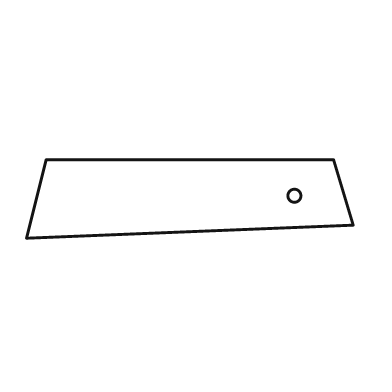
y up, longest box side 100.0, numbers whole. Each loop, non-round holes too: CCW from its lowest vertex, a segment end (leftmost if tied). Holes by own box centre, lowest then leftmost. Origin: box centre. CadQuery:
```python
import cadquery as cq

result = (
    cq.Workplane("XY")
    .moveTo(-50.0, -12.0)
    .lineTo(50.0, -8.0)
    .lineTo(44.0, 12.0)
    .lineTo(-44.0, 12.0)
    .close()
    .moveTo(32.0, 1.0)
    .circle(2.0)
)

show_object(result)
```